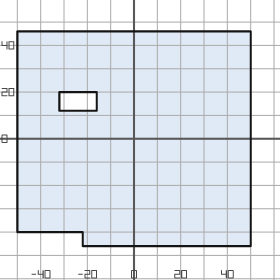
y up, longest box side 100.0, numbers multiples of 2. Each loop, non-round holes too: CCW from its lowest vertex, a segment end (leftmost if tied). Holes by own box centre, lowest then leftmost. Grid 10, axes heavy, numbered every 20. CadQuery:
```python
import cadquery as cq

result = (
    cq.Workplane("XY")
    .moveTo(-22.0, -46.0)
    .lineTo(50.0, -46.0)
    .lineTo(50.0, 46.0)
    .lineTo(-50.0, 46.0)
    .lineTo(-50.0, -40.0)
    .lineTo(-22.0, -40.0)
    .close()
    .moveTo(-32.0, 12.0)
    .lineTo(-16.0, 12.0)
    .lineTo(-16.0, 20.0)
    .lineTo(-32.0, 20.0)
    .close()
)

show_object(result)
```